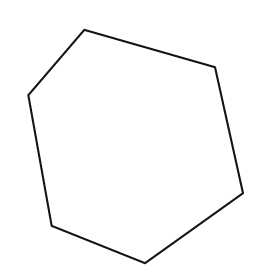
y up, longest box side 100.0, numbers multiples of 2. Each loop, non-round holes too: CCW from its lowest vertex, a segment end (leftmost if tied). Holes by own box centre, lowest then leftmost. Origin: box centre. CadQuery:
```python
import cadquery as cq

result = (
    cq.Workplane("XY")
    .moveTo(4.0, -50.0)
    .lineTo(46.0, -20.0)
    .lineTo(34.0, 34.0)
    .lineTo(-22.0, 50.0)
    .lineTo(-46.0, 22.0)
    .lineTo(-36.0, -34.0)
    .close()
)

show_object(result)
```